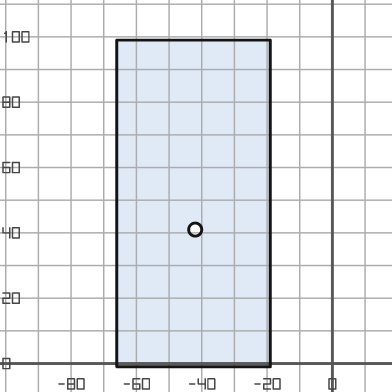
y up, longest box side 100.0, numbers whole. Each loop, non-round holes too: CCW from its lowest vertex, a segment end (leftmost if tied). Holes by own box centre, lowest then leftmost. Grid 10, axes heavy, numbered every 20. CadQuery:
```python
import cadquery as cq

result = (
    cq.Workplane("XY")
    .moveTo(-66.0, -1.0)
    .lineTo(-19.0, -1.0)
    .lineTo(-19.0, 99.0)
    .lineTo(-66.0, 99.0)
    .close()
    .moveTo(-42.0, 41.0)
    .circle(2.0)
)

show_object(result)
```